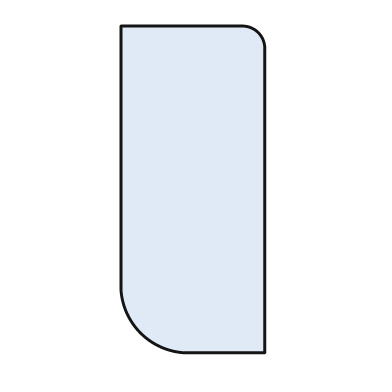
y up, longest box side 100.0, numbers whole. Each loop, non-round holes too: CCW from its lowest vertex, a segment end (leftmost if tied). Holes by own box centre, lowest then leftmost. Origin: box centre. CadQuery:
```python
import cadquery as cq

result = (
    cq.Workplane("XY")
    .moveTo(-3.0, -50.0)
    .lineTo(22.0, -50.0)
    .lineTo(22.0, 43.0)
    .threePointArc((20.0, 48.0), (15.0, 50.0))
    .lineTo(-22.0, 50.0)
    .lineTo(-22.0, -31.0)
    .threePointArc((-16.0, -44.0), (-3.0, -50.0))
    .close()
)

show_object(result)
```